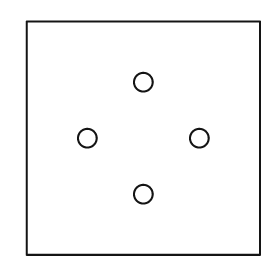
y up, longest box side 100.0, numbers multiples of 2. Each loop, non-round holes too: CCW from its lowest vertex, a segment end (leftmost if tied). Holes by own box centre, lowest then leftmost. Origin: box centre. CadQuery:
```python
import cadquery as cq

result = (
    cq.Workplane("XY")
    .moveTo(-50.0, -50.0)
    .lineTo(50.0, -50.0)
    .lineTo(50.0, 50.0)
    .lineTo(-50.0, 50.0)
    .close()
    .moveTo(0.0, -24.0)
    .circle(4.0)
    .moveTo(-24.0, 0.0)
    .circle(4.0)
    .moveTo(24.0, 0.0)
    .circle(4.0)
    .moveTo(0.0, 24.0)
    .circle(4.0)
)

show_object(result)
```